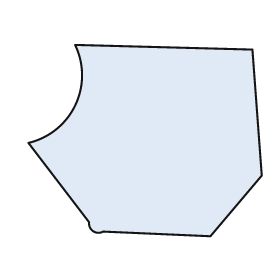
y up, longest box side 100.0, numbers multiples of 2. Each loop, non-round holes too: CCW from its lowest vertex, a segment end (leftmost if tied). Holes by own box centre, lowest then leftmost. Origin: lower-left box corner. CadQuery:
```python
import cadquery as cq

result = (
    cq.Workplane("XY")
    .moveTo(78.0, 0.0)
    .lineTo(100.0, 26.0)
    .lineTo(96.0, 80.0)
    .lineTo(20.0, 82.0)
    .threePointArc((20.0, 56.0), (0.0, 40.0))
    .lineTo(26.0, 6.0)
    .threePointArc((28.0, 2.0), (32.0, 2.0))
    .close()
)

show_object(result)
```